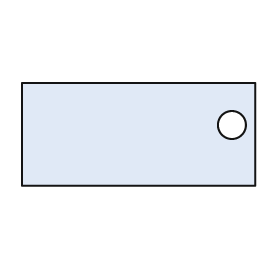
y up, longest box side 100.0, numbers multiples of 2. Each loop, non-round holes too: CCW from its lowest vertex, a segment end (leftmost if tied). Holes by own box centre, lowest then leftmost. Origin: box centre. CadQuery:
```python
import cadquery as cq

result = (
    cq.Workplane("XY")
    .moveTo(-50.0, -22.0)
    .lineTo(50.0, -22.0)
    .lineTo(50.0, 22.0)
    .lineTo(-50.0, 22.0)
    .close()
    .moveTo(40.0, 4.0)
    .circle(6.0)
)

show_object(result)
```